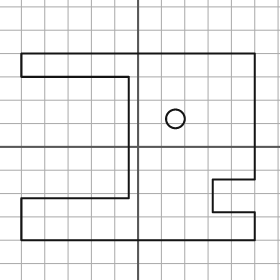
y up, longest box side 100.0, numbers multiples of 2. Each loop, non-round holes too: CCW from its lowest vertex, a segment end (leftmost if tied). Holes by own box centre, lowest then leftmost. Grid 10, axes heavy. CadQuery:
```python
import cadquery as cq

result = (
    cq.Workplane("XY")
    .moveTo(-50.0, -40.0)
    .lineTo(50.0, -40.0)
    .lineTo(50.0, -28.0)
    .lineTo(32.0, -28.0)
    .lineTo(32.0, -14.0)
    .lineTo(50.0, -14.0)
    .lineTo(50.0, 40.0)
    .lineTo(-50.0, 40.0)
    .lineTo(-50.0, 30.0)
    .lineTo(-4.0, 30.0)
    .lineTo(-4.0, -22.0)
    .lineTo(-50.0, -22.0)
    .close()
    .moveTo(16.0, 12.0)
    .circle(4.0)
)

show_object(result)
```